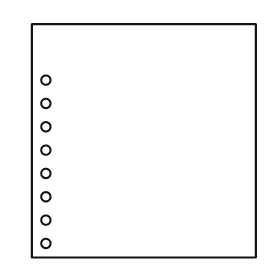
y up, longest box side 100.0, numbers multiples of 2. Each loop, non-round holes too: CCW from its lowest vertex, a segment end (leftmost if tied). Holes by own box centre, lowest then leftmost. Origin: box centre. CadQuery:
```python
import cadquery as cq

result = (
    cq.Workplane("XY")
    .moveTo(-48.0, -50.0)
    .lineTo(48.0, -50.0)
    .lineTo(48.0, 50.0)
    .lineTo(-48.0, 50.0)
    .close()
    .moveTo(-42.0, -44.0)
    .circle(2.0)
    .moveTo(-42.0, -34.0)
    .circle(2.0)
    .moveTo(-42.0, -24.0)
    .circle(2.0)
    .moveTo(-42.0, -14.0)
    .circle(2.0)
    .moveTo(-42.0, -4.0)
    .circle(2.0)
    .moveTo(-42.0, 6.0)
    .circle(2.0)
    .moveTo(-42.0, 16.0)
    .circle(2.0)
    .moveTo(-42.0, 26.0)
    .circle(2.0)
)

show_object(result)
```